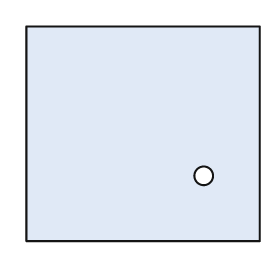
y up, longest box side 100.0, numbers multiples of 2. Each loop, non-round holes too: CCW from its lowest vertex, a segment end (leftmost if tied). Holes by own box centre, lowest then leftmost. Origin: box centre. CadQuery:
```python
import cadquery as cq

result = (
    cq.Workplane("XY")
    .moveTo(-50.0, -46.0)
    .lineTo(50.0, -46.0)
    .lineTo(50.0, 46.0)
    .lineTo(-50.0, 46.0)
    .close()
    .moveTo(26.0, -18.0)
    .circle(4.0)
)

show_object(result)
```